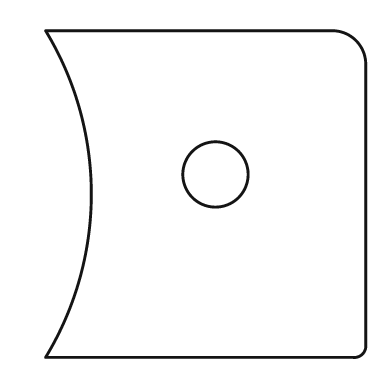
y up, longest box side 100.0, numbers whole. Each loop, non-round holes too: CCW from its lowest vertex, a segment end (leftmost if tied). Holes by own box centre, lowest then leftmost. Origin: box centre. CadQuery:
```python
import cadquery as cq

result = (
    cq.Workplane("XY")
    .moveTo(-49.0, -50.0)
    .lineTo(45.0, -50.0)
    .threePointArc((48.0, -49.0), (49.0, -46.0))
    .lineTo(49.0, 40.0)
    .threePointArc((46.0, 47.0), (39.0, 50.0))
    .lineTo(-49.0, 50.0)
    .threePointArc((-35.0, 0.0), (-49.0, -50.0))
    .close()
    .moveTo(3.0, 6.0)
    .circle(10.0)
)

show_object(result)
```